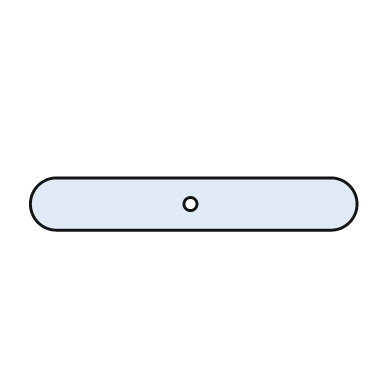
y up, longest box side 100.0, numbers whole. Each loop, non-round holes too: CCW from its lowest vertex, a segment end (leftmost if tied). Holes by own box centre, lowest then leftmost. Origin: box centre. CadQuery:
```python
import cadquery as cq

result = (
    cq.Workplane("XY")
    .moveTo(-42.0, -8.0)
    .lineTo(42.0, -8.0)
    .threePointArc((50.0, 0.0), (42.0, 8.0))
    .lineTo(-42.0, 8.0)
    .threePointArc((-50.0, 0.0), (-42.0, -8.0))
    .close()
    .moveTo(-1.0, 0.0)
    .circle(2.0)
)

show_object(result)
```